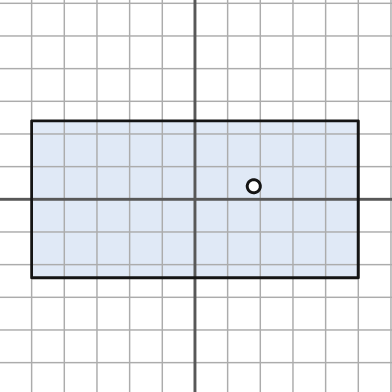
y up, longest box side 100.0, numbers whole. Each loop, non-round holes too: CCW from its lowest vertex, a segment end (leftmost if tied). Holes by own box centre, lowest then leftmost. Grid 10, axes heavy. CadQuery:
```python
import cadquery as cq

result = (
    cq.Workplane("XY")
    .moveTo(-50.0, -24.0)
    .lineTo(50.0, -24.0)
    .lineTo(50.0, 24.0)
    .lineTo(-50.0, 24.0)
    .close()
    .moveTo(18.0, 4.0)
    .circle(2.0)
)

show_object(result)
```